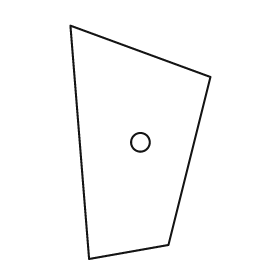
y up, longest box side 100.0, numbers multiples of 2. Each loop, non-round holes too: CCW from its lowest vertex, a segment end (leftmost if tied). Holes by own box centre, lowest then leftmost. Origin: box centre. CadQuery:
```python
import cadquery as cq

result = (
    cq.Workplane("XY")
    .moveTo(-22.0, -50.0)
    .lineTo(12.0, -44.0)
    .lineTo(30.0, 28.0)
    .lineTo(-30.0, 50.0)
    .close()
    .moveTo(0.0, 0.0)
    .circle(4.0)
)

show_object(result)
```